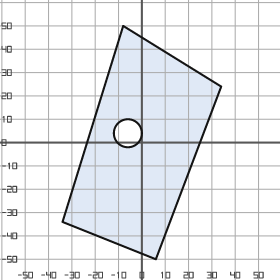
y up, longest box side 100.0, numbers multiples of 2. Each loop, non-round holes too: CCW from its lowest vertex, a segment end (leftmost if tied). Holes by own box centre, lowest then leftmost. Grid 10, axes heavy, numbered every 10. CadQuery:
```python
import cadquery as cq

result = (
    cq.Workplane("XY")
    .moveTo(6.0, -50.0)
    .lineTo(34.0, 24.0)
    .lineTo(-8.0, 50.0)
    .lineTo(-34.0, -34.0)
    .close()
    .moveTo(-6.0, 4.0)
    .circle(6.0)
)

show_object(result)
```